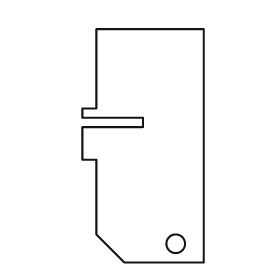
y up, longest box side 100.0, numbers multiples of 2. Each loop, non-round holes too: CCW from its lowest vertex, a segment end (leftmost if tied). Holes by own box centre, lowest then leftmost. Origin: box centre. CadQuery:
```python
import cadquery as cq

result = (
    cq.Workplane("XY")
    .moveTo(-8.0, -50.0)
    .lineTo(26.0, -50.0)
    .lineTo(26.0, 50.0)
    .lineTo(-20.0, 50.0)
    .lineTo(-20.0, 16.0)
    .lineTo(-26.0, 16.0)
    .lineTo(-26.0, 12.0)
    .lineTo(0.0, 12.0)
    .lineTo(0.0, 8.0)
    .lineTo(-26.0, 8.0)
    .lineTo(-26.0, -6.0)
    .lineTo(-20.0, -6.0)
    .lineTo(-20.0, -38.0)
    .close()
    .moveTo(14.0, -42.0)
    .circle(4.0)
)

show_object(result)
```